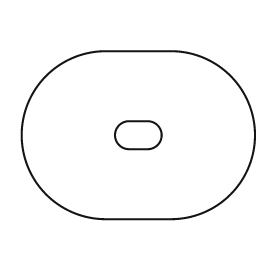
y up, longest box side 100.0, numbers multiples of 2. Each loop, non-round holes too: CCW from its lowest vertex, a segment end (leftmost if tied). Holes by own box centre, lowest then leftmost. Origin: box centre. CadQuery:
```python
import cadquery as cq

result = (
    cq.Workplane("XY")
    .moveTo(-14.0, -36.0)
    .lineTo(14.0, -36.0)
    .threePointArc((50.0, 0.0), (14.0, 36.0))
    .lineTo(-14.0, 36.0)
    .threePointArc((-50.0, 0.0), (-14.0, -36.0))
    .close()
    .moveTo(-4.0, -6.0)
    .lineTo(4.0, -6.0)
    .threePointArc((10.0, 0.0), (4.0, 6.0))
    .lineTo(-4.0, 6.0)
    .threePointArc((-10.0, 0.0), (-4.0, -6.0))
    .close()
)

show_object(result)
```